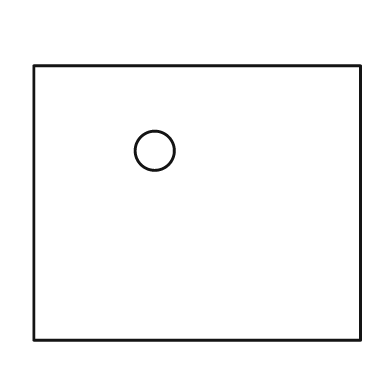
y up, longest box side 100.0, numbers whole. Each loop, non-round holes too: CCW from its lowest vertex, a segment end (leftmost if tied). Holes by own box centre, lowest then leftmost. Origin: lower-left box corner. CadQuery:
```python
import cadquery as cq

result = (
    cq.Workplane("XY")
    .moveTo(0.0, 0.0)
    .lineTo(100.0, 0.0)
    .lineTo(100.0, 84.0)
    .lineTo(0.0, 84.0)
    .close()
    .moveTo(37.0, 58.0)
    .circle(6.0)
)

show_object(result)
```